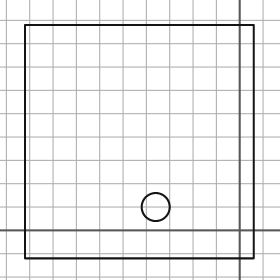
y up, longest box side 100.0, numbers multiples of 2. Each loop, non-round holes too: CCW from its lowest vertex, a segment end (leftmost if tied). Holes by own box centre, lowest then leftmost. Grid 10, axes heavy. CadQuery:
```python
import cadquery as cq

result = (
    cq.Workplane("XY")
    .moveTo(-92.0, -12.0)
    .lineTo(6.0, -12.0)
    .lineTo(6.0, 88.0)
    .lineTo(-92.0, 88.0)
    .close()
    .moveTo(-36.0, 10.0)
    .circle(6.0)
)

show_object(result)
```